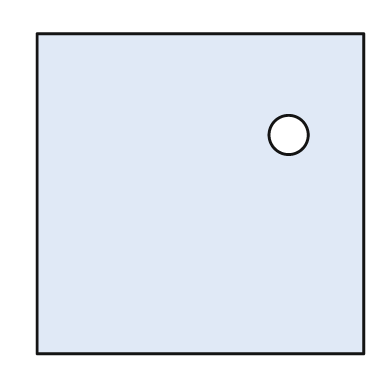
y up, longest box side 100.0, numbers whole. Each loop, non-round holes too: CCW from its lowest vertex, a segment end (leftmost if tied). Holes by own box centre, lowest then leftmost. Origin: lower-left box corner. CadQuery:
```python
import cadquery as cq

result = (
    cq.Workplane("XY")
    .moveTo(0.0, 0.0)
    .lineTo(100.0, 0.0)
    .lineTo(100.0, 98.0)
    .lineTo(0.0, 98.0)
    .close()
    .moveTo(77.0, 67.0)
    .circle(6.0)
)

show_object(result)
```